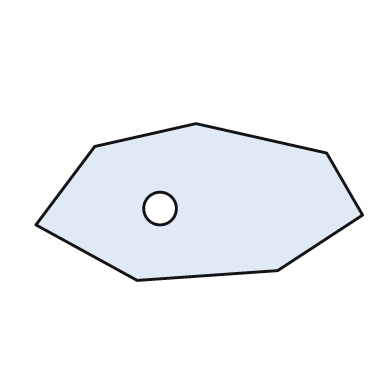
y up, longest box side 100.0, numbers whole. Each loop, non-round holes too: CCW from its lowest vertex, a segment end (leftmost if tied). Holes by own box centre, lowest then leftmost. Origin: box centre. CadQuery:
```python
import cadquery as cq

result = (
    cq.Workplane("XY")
    .moveTo(-19.0, -24.0)
    .lineTo(24.0, -21.0)
    .lineTo(50.0, -4.0)
    .lineTo(39.0, 15.0)
    .lineTo(-1.0, 24.0)
    .lineTo(-32.0, 17.0)
    .lineTo(-50.0, -7.0)
    .close()
    .moveTo(-12.0, -2.0)
    .circle(5.0)
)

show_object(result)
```